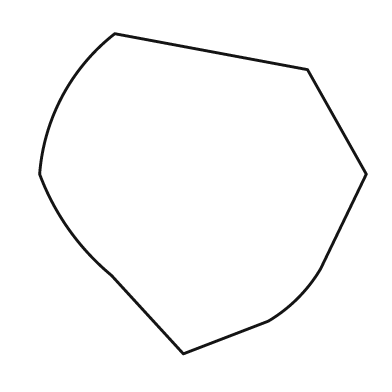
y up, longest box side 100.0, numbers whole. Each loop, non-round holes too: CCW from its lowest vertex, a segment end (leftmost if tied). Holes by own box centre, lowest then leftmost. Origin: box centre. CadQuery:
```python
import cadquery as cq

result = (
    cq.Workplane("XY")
    .moveTo(-6.0, -49.0)
    .lineTo(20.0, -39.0)
    .threePointArc((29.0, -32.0), (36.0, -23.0))
    .lineTo(50.0, 6.0)
    .lineTo(32.0, 38.0)
    .lineTo(-27.0, 49.0)
    .threePointArc((-43.0, 30.0), (-50.0, 6.0))
    .threePointArc((-41.0, -11.0), (-28.0, -25.0))
    .close()
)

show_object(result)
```